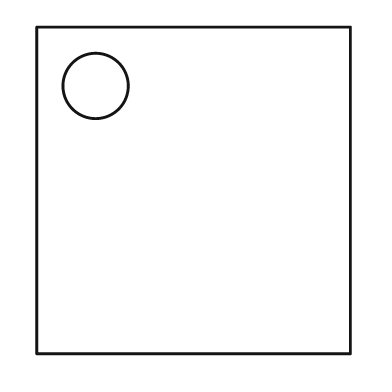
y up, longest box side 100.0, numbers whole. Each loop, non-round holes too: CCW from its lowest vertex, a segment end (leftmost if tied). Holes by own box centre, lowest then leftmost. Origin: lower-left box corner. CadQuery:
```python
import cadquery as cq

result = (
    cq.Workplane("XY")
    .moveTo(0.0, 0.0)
    .lineTo(96.0, 0.0)
    .lineTo(96.0, 100.0)
    .lineTo(0.0, 100.0)
    .close()
    .moveTo(18.0, 82.0)
    .circle(10.0)
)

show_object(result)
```